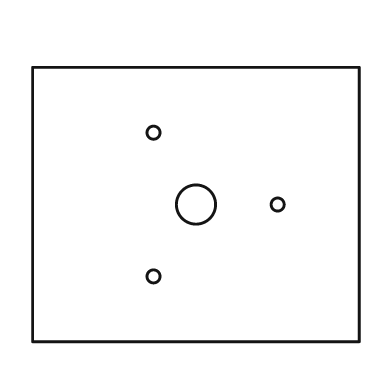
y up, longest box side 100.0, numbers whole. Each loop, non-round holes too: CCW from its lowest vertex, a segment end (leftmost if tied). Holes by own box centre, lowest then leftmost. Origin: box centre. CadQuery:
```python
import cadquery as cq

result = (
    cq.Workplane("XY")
    .moveTo(-50.0, -42.0)
    .lineTo(50.0, -42.0)
    .lineTo(50.0, 42.0)
    .lineTo(-50.0, 42.0)
    .close()
    .moveTo(-13.0, -22.0)
    .circle(2.0)
    .moveTo(0.0, 0.0)
    .circle(6.0)
    .moveTo(25.0, 0.0)
    .circle(2.0)
    .moveTo(-13.0, 22.0)
    .circle(2.0)
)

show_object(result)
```